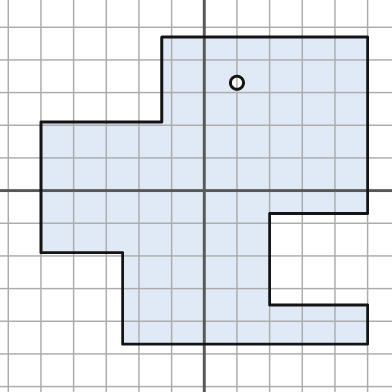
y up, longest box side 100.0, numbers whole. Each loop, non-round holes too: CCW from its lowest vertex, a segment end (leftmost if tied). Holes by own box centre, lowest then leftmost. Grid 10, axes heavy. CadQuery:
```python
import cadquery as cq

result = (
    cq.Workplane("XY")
    .moveTo(-25.0, -47.0)
    .lineTo(50.0, -47.0)
    .lineTo(50.0, -35.0)
    .lineTo(20.0, -35.0)
    .lineTo(20.0, -7.0)
    .lineTo(50.0, -7.0)
    .lineTo(50.0, 47.0)
    .lineTo(-13.0, 47.0)
    .lineTo(-13.0, 21.0)
    .lineTo(-50.0, 21.0)
    .lineTo(-50.0, -19.0)
    .lineTo(-25.0, -19.0)
    .close()
    .moveTo(10.0, 33.0)
    .circle(2.0)
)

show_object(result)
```